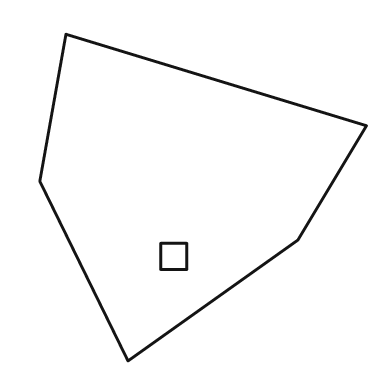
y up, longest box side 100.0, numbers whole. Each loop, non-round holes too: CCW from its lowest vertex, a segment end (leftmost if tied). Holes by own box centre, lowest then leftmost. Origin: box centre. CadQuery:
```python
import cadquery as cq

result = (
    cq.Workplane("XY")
    .moveTo(-23.0, -50.0)
    .lineTo(29.0, -13.0)
    .lineTo(50.0, 22.0)
    .lineTo(-42.0, 50.0)
    .lineTo(-50.0, 5.0)
    .close()
    .moveTo(-13.0, -22.0)
    .lineTo(-5.0, -22.0)
    .lineTo(-5.0, -14.0)
    .lineTo(-13.0, -14.0)
    .close()
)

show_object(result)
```